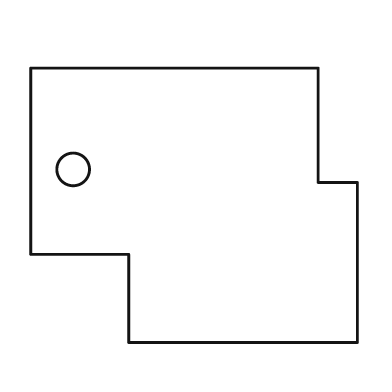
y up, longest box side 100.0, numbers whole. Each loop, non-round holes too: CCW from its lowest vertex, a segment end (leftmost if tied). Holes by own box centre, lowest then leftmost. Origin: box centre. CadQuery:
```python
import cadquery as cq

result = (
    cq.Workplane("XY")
    .moveTo(-20.0, -42.0)
    .lineTo(50.0, -42.0)
    .lineTo(50.0, 7.0)
    .lineTo(38.0, 7.0)
    .lineTo(38.0, 42.0)
    .lineTo(-50.0, 42.0)
    .lineTo(-50.0, -15.0)
    .lineTo(-20.0, -15.0)
    .close()
    .moveTo(-37.0, 11.0)
    .circle(5.0)
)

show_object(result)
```